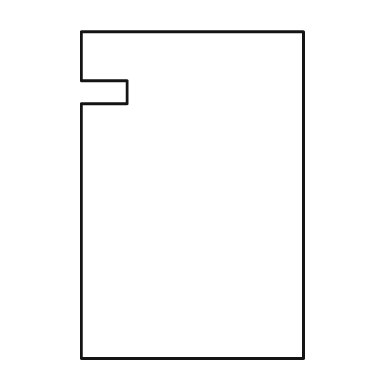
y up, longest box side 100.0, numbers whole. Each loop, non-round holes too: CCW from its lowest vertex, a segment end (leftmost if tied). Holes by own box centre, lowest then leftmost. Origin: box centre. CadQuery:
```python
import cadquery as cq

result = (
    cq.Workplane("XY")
    .moveTo(-34.0, -50.0)
    .lineTo(34.0, -50.0)
    .lineTo(34.0, 50.0)
    .lineTo(-34.0, 50.0)
    .lineTo(-34.0, 35.0)
    .lineTo(-20.0, 35.0)
    .lineTo(-20.0, 28.0)
    .lineTo(-34.0, 28.0)
    .close()
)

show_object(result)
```